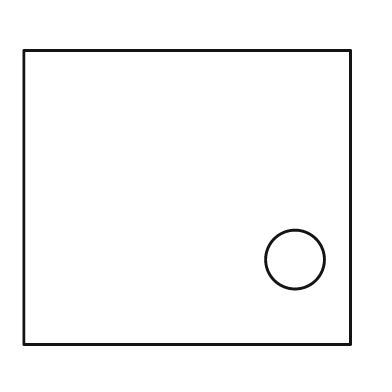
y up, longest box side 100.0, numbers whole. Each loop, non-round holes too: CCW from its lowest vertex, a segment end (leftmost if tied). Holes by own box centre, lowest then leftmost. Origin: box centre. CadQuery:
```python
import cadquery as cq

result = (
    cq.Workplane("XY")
    .moveTo(-50.0, -45.0)
    .lineTo(50.0, -45.0)
    .lineTo(50.0, 45.0)
    .lineTo(-50.0, 45.0)
    .close()
    .moveTo(33.0, -19.0)
    .circle(9.0)
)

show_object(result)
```